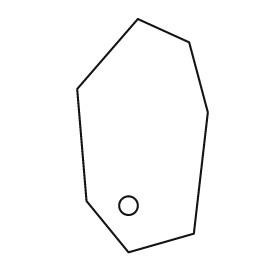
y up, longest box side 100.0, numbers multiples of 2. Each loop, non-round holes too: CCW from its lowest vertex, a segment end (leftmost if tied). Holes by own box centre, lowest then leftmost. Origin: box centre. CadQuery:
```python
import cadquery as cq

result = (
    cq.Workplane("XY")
    .moveTo(-6.0, -50.0)
    .lineTo(22.0, -42.0)
    .lineTo(28.0, 10.0)
    .lineTo(20.0, 40.0)
    .lineTo(-2.0, 50.0)
    .lineTo(-28.0, 20.0)
    .lineTo(-24.0, -28.0)
    .close()
    .moveTo(-6.0, -30.0)
    .circle(4.0)
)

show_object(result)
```